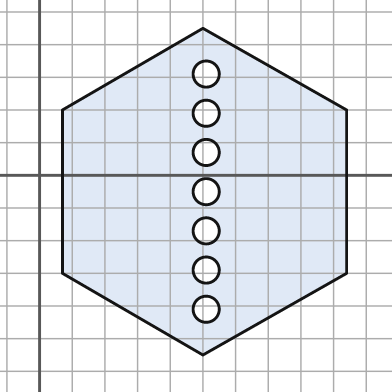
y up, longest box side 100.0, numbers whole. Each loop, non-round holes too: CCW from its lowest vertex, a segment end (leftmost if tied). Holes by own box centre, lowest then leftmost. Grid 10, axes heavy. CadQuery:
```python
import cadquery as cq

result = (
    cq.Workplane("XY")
    .moveTo(50.0, -55.0)
    .lineTo(94.0, -30.0)
    .lineTo(94.0, 20.0)
    .lineTo(50.0, 45.0)
    .lineTo(7.0, 20.0)
    .lineTo(7.0, -30.0)
    .close()
    .moveTo(51.0, -41.0)
    .circle(4.0)
    .moveTo(51.0, -29.0)
    .circle(4.0)
    .moveTo(51.0, -17.0)
    .circle(4.0)
    .moveTo(51.0, -5.0)
    .circle(4.0)
    .moveTo(51.0, 7.0)
    .circle(4.0)
    .moveTo(51.0, 19.0)
    .circle(4.0)
    .moveTo(51.0, 31.0)
    .circle(4.0)
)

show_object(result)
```